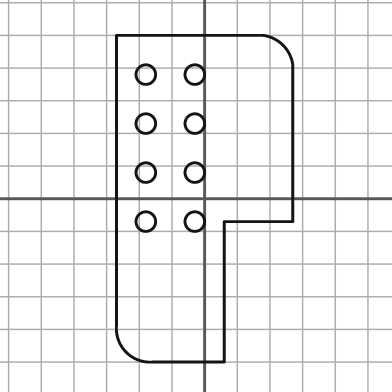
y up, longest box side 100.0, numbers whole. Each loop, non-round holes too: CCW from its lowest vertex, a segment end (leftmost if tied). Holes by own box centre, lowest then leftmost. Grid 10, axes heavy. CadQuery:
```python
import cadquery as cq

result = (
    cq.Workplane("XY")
    .moveTo(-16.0, -50.0)
    .lineTo(6.0, -50.0)
    .lineTo(6.0, -7.0)
    .lineTo(27.0, -7.0)
    .lineTo(27.0, 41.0)
    .threePointArc((24.0, 47.0), (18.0, 50.0))
    .lineTo(-27.0, 50.0)
    .lineTo(-27.0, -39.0)
    .threePointArc((-24.0, -47.0), (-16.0, -50.0))
    .close()
    .moveTo(-18.0, -7.0)
    .circle(3.0)
    .moveTo(-3.0, -7.0)
    .circle(3.0)
    .moveTo(-18.0, 8.0)
    .circle(3.0)
    .moveTo(-3.0, 8.0)
    .circle(3.0)
    .moveTo(-18.0, 23.0)
    .circle(3.0)
    .moveTo(-3.0, 23.0)
    .circle(3.0)
    .moveTo(-18.0, 38.0)
    .circle(3.0)
    .moveTo(-3.0, 38.0)
    .circle(3.0)
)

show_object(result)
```